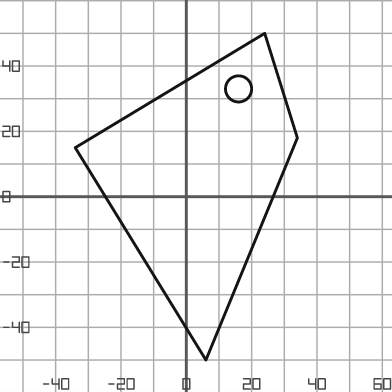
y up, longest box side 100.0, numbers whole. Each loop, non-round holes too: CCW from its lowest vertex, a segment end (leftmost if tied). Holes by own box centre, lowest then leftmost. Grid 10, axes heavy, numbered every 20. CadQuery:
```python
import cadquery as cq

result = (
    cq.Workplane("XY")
    .moveTo(6.0, -50.0)
    .lineTo(34.0, 18.0)
    .lineTo(24.0, 50.0)
    .lineTo(-34.0, 15.0)
    .close()
    .moveTo(16.0, 33.0)
    .circle(4.0)
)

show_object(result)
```